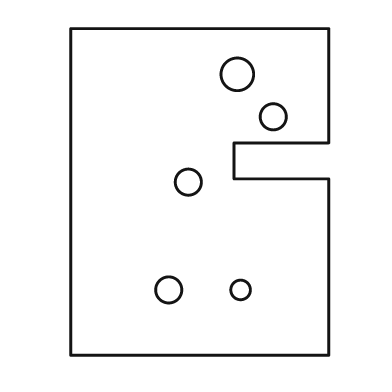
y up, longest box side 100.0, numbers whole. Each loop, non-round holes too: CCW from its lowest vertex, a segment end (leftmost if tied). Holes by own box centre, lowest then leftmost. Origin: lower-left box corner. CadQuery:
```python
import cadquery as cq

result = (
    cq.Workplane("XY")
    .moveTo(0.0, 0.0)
    .lineTo(79.0, 0.0)
    .lineTo(79.0, 54.0)
    .lineTo(50.0, 54.0)
    .lineTo(50.0, 65.0)
    .lineTo(79.0, 65.0)
    .lineTo(79.0, 100.0)
    .lineTo(0.0, 100.0)
    .close()
    .moveTo(30.0, 20.0)
    .circle(4.0)
    .moveTo(52.0, 20.0)
    .circle(3.0)
    .moveTo(36.0, 53.0)
    .circle(4.0)
    .moveTo(62.0, 73.0)
    .circle(4.0)
    .moveTo(51.0, 86.0)
    .circle(5.0)
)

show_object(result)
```